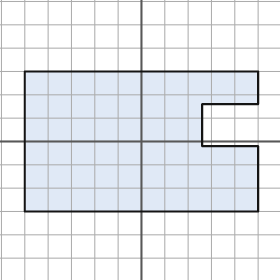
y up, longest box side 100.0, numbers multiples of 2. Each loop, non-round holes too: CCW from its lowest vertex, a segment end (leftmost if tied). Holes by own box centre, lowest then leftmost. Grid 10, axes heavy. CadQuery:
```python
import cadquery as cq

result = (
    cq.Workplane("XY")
    .moveTo(-50.0, -30.0)
    .lineTo(50.0, -30.0)
    .lineTo(50.0, -2.0)
    .lineTo(26.0, -2.0)
    .lineTo(26.0, 16.0)
    .lineTo(50.0, 16.0)
    .lineTo(50.0, 30.0)
    .lineTo(-50.0, 30.0)
    .close()
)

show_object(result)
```